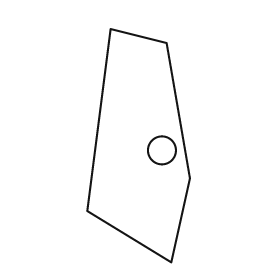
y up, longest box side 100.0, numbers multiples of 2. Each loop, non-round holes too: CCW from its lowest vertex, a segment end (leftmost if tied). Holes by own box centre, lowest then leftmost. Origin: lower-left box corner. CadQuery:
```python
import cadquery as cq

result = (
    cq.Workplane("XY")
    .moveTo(36.0, 0.0)
    .lineTo(44.0, 36.0)
    .lineTo(34.0, 94.0)
    .lineTo(10.0, 100.0)
    .lineTo(0.0, 22.0)
    .close()
    .moveTo(32.0, 48.0)
    .circle(6.0)
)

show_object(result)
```